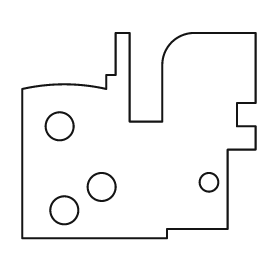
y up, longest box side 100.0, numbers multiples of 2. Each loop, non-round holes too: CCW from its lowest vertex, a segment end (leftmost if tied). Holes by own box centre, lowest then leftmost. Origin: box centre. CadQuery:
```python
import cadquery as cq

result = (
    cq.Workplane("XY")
    .moveTo(-50.0, -44.0)
    .lineTo(12.0, -44.0)
    .lineTo(12.0, -40.0)
    .lineTo(38.0, -40.0)
    .lineTo(38.0, -6.0)
    .lineTo(50.0, -6.0)
    .lineTo(50.0, 4.0)
    .lineTo(42.0, 4.0)
    .lineTo(42.0, 14.0)
    .lineTo(50.0, 14.0)
    .lineTo(50.0, 44.0)
    .lineTo(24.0, 44.0)
    .threePointArc((14.0, 40.0), (10.0, 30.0))
    .lineTo(10.0, 6.0)
    .lineTo(-4.0, 6.0)
    .lineTo(-4.0, 44.0)
    .lineTo(-10.0, 44.0)
    .lineTo(-10.0, 26.0)
    .lineTo(-14.0, 26.0)
    .lineTo(-14.0, 20.0)
    .threePointArc((-32.0, 22.0), (-50.0, 20.0))
    .close()
    .moveTo(-32.0, -32.0)
    .circle(6.0)
    .moveTo(-16.0, -22.0)
    .circle(6.0)
    .moveTo(30.0, -20.0)
    .circle(4.0)
    .moveTo(-34.0, 4.0)
    .circle(6.0)
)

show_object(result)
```